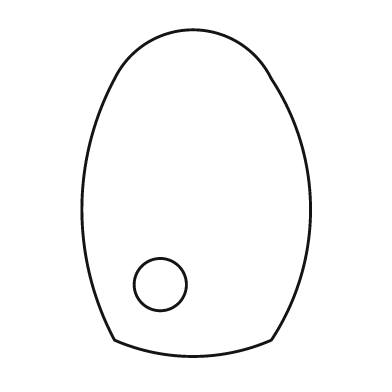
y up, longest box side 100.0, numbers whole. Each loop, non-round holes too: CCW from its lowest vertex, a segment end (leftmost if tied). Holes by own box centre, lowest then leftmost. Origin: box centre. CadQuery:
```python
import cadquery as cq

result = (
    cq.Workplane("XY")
    .moveTo(-25.0, -45.0)
    .threePointArc((-1.0, -50.0), (23.0, -45.0))
    .threePointArc((35.0, -5.0), (23.0, 35.0))
    .threePointArc((-1.0, 50.0), (-25.0, 35.0))
    .threePointArc((-35.0, -5.0), (-25.0, -45.0))
    .close()
    .moveTo(-11.0, -28.0)
    .circle(8.0)
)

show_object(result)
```